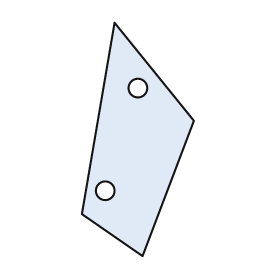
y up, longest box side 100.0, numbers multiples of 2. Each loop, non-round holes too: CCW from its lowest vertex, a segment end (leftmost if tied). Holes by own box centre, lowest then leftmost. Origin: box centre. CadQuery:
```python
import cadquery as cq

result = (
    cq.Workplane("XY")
    .moveTo(2.0, -50.0)
    .lineTo(24.0, 8.0)
    .lineTo(-10.0, 50.0)
    .lineTo(-24.0, -32.0)
    .close()
    .moveTo(-14.0, -22.0)
    .circle(4.0)
    .moveTo(0.0, 22.0)
    .circle(4.0)
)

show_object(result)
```